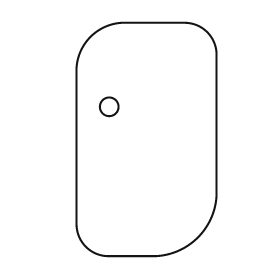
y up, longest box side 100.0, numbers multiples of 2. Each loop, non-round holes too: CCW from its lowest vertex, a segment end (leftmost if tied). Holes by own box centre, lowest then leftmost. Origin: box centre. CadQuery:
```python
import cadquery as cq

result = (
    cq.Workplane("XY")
    .moveTo(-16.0, -50.0)
    .lineTo(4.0, -50.0)
    .threePointArc((22.0, -42.0), (30.0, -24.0))
    .lineTo(30.0, 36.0)
    .threePointArc((26.0, 46.0), (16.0, 50.0))
    .lineTo(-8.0, 50.0)
    .threePointArc((-24.0, 44.0), (-30.0, 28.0))
    .lineTo(-30.0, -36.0)
    .threePointArc((-26.0, -46.0), (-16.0, -50.0))
    .close()
    .moveTo(-16.0, 14.0)
    .circle(4.0)
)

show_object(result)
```